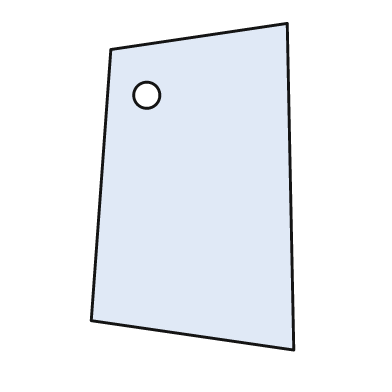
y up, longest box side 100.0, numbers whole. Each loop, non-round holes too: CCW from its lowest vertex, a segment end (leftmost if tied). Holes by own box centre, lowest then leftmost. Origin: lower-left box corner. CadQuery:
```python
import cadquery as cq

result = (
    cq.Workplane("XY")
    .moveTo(62.0, 0.0)
    .lineTo(60.0, 100.0)
    .lineTo(6.0, 92.0)
    .lineTo(0.0, 9.0)
    .close()
    .moveTo(17.0, 78.0)
    .circle(4.0)
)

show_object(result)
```